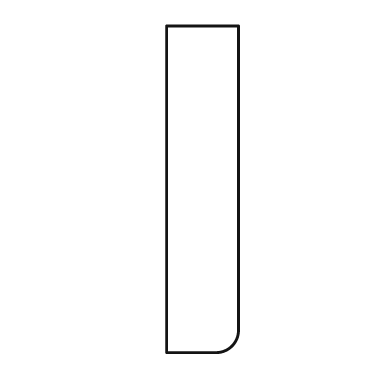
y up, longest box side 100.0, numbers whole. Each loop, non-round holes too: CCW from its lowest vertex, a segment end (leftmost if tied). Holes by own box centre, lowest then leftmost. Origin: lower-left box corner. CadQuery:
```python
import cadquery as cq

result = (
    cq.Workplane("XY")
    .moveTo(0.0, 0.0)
    .lineTo(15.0, 0.0)
    .threePointArc((20.0, 2.0), (22.0, 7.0))
    .lineTo(22.0, 100.0)
    .lineTo(0.0, 100.0)
    .close()
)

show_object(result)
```